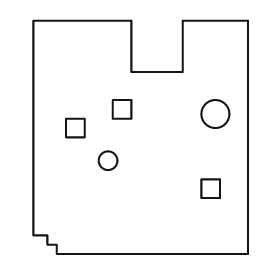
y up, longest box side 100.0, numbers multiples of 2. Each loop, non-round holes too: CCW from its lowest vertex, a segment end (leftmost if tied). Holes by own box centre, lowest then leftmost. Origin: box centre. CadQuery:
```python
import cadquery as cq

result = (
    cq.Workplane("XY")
    .moveTo(-36.0, -50.0)
    .lineTo(46.0, -50.0)
    .lineTo(46.0, 50.0)
    .lineTo(18.0, 50.0)
    .lineTo(18.0, 28.0)
    .lineTo(-4.0, 28.0)
    .lineTo(-4.0, 50.0)
    .lineTo(-46.0, 50.0)
    .lineTo(-46.0, -42.0)
    .lineTo(-40.0, -42.0)
    .lineTo(-40.0, -46.0)
    .lineTo(-36.0, -46.0)
    .close()
    .moveTo(26.0, -26.0)
    .lineTo(34.0, -26.0)
    .lineTo(34.0, -18.0)
    .lineTo(26.0, -18.0)
    .close()
    .moveTo(-14.0, -10.0)
    .circle(4.0)
    .moveTo(-32.0, 0.0)
    .lineTo(-24.0, 0.0)
    .lineTo(-24.0, 8.0)
    .lineTo(-32.0, 8.0)
    .close()
    .moveTo(32.0, 10.0)
    .circle(6.0)
    .moveTo(-12.0, 8.0)
    .lineTo(-4.0, 8.0)
    .lineTo(-4.0, 16.0)
    .lineTo(-12.0, 16.0)
    .close()
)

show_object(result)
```